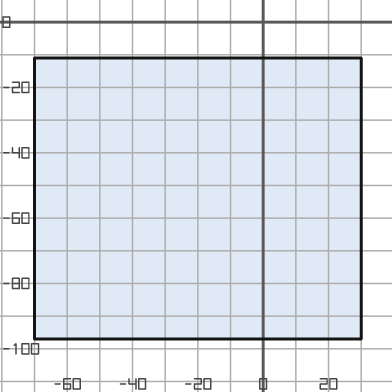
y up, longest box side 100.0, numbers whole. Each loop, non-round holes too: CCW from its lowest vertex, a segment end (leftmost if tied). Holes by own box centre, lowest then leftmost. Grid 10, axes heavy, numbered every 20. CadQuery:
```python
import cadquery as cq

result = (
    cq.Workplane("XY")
    .moveTo(-70.0, -97.0)
    .lineTo(30.0, -97.0)
    .lineTo(30.0, -11.0)
    .lineTo(-70.0, -11.0)
    .close()
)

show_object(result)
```